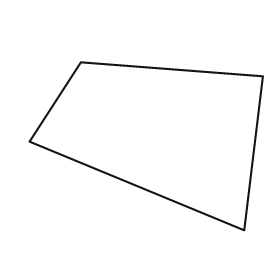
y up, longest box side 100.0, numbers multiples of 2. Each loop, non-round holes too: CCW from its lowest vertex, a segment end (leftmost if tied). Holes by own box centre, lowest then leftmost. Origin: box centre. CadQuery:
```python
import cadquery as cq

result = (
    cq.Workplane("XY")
    .moveTo(42.0, -36.0)
    .lineTo(50.0, 30.0)
    .lineTo(-28.0, 36.0)
    .lineTo(-50.0, 2.0)
    .close()
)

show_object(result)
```